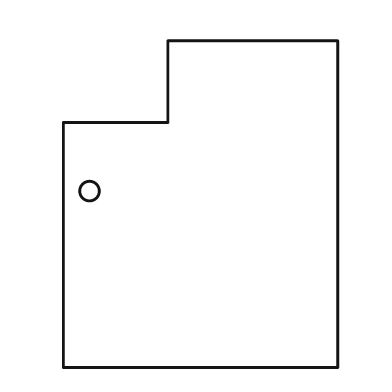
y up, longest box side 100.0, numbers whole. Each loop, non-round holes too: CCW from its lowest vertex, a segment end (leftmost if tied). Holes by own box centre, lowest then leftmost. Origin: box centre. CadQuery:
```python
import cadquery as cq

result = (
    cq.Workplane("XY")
    .moveTo(-42.0, -50.0)
    .lineTo(42.0, -50.0)
    .lineTo(42.0, 50.0)
    .lineTo(-10.0, 50.0)
    .lineTo(-10.0, 25.0)
    .lineTo(-42.0, 25.0)
    .close()
    .moveTo(-34.0, 4.0)
    .circle(3.0)
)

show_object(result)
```